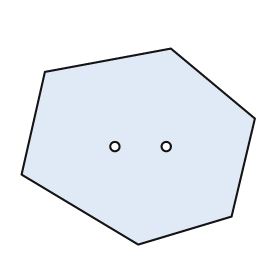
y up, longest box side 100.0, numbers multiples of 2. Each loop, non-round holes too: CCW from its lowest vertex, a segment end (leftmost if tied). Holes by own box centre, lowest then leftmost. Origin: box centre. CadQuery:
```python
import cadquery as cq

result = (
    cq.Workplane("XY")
    .moveTo(0.0, -42.0)
    .lineTo(40.0, -30.0)
    .lineTo(50.0, 12.0)
    .lineTo(14.0, 42.0)
    .lineTo(-40.0, 32.0)
    .lineTo(-50.0, -12.0)
    .close()
    .moveTo(-10.0, 0.0)
    .circle(2.0)
    .moveTo(12.0, 0.0)
    .circle(2.0)
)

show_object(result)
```